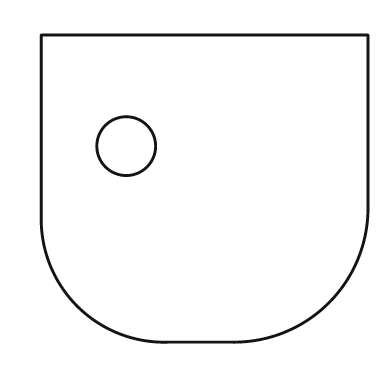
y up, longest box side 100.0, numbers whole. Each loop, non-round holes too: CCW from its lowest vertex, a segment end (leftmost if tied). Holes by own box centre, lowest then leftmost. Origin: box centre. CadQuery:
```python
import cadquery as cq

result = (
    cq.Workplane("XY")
    .moveTo(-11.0, -47.0)
    .lineTo(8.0, -47.0)
    .threePointArc((38.0, -35.0), (50.0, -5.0))
    .lineTo(50.0, 47.0)
    .lineTo(-50.0, 47.0)
    .lineTo(-50.0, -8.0)
    .threePointArc((-39.0, -36.0), (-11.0, -47.0))
    .close()
    .moveTo(-24.0, 13.0)
    .circle(9.0)
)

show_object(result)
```